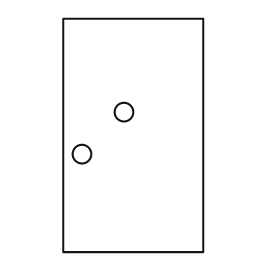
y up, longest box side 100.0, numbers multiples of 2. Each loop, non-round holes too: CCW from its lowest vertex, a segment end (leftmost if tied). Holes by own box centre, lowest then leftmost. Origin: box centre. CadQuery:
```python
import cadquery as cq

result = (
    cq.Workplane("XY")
    .moveTo(-30.0, -50.0)
    .lineTo(30.0, -50.0)
    .lineTo(30.0, 50.0)
    .lineTo(-30.0, 50.0)
    .close()
    .moveTo(-22.0, -8.0)
    .circle(4.0)
    .moveTo(-4.0, 10.0)
    .circle(4.0)
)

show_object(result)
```